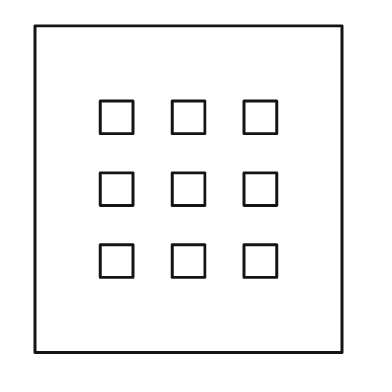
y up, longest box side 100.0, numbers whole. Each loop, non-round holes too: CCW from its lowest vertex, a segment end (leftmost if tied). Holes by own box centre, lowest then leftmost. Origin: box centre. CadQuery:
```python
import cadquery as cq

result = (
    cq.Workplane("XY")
    .moveTo(-47.0, -50.0)
    .lineTo(47.0, -50.0)
    .lineTo(47.0, 50.0)
    .lineTo(-47.0, 50.0)
    .close()
    .moveTo(-27.0, -27.0)
    .lineTo(-17.0, -27.0)
    .lineTo(-17.0, -17.0)
    .lineTo(-27.0, -17.0)
    .close()
    .moveTo(-5.0, -27.0)
    .lineTo(5.0, -27.0)
    .lineTo(5.0, -17.0)
    .lineTo(-5.0, -17.0)
    .close()
    .moveTo(17.0, -27.0)
    .lineTo(27.0, -27.0)
    .lineTo(27.0, -17.0)
    .lineTo(17.0, -17.0)
    .close()
    .moveTo(-27.0, -5.0)
    .lineTo(-17.0, -5.0)
    .lineTo(-17.0, 5.0)
    .lineTo(-27.0, 5.0)
    .close()
    .moveTo(-5.0, -5.0)
    .lineTo(5.0, -5.0)
    .lineTo(5.0, 5.0)
    .lineTo(-5.0, 5.0)
    .close()
    .moveTo(17.0, -5.0)
    .lineTo(27.0, -5.0)
    .lineTo(27.0, 5.0)
    .lineTo(17.0, 5.0)
    .close()
    .moveTo(-27.0, 17.0)
    .lineTo(-17.0, 17.0)
    .lineTo(-17.0, 27.0)
    .lineTo(-27.0, 27.0)
    .close()
    .moveTo(-5.0, 17.0)
    .lineTo(5.0, 17.0)
    .lineTo(5.0, 27.0)
    .lineTo(-5.0, 27.0)
    .close()
    .moveTo(17.0, 17.0)
    .lineTo(27.0, 17.0)
    .lineTo(27.0, 27.0)
    .lineTo(17.0, 27.0)
    .close()
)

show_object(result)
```